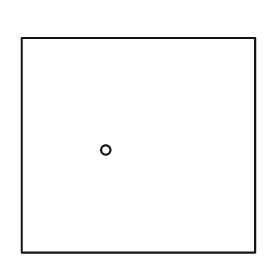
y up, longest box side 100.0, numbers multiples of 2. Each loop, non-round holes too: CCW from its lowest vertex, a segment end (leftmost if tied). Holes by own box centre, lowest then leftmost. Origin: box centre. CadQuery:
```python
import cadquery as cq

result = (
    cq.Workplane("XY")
    .moveTo(-50.0, -46.0)
    .lineTo(50.0, -46.0)
    .lineTo(50.0, 46.0)
    .lineTo(-50.0, 46.0)
    .close()
    .moveTo(-14.0, -2.0)
    .circle(2.0)
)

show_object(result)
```